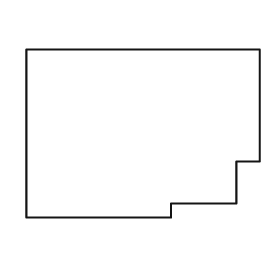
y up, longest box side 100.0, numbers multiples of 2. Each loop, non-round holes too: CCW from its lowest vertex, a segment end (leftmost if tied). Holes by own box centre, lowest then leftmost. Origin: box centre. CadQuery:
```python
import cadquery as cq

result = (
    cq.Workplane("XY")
    .moveTo(-50.0, -36.0)
    .lineTo(12.0, -36.0)
    .lineTo(12.0, -30.0)
    .lineTo(40.0, -30.0)
    .lineTo(40.0, -12.0)
    .lineTo(50.0, -12.0)
    .lineTo(50.0, 36.0)
    .lineTo(-50.0, 36.0)
    .close()
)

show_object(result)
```